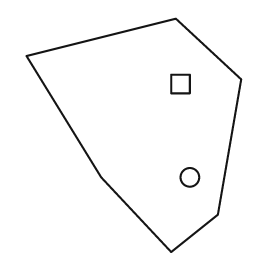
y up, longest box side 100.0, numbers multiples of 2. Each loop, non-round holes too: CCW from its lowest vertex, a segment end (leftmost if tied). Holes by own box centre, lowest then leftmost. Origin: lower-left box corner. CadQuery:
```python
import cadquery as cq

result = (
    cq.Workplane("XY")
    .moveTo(62.0, 0.0)
    .lineTo(82.0, 16.0)
    .lineTo(92.0, 74.0)
    .lineTo(64.0, 100.0)
    .lineTo(0.0, 84.0)
    .lineTo(32.0, 32.0)
    .close()
    .moveTo(70.0, 32.0)
    .circle(4.0)
    .moveTo(62.0, 68.0)
    .lineTo(70.0, 68.0)
    .lineTo(70.0, 76.0)
    .lineTo(62.0, 76.0)
    .close()
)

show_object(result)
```